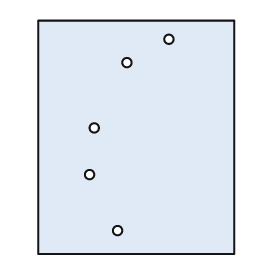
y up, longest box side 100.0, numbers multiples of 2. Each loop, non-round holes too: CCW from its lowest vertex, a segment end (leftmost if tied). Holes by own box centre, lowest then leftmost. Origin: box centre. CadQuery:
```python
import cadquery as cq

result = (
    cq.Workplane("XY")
    .moveTo(-42.0, -50.0)
    .lineTo(42.0, -50.0)
    .lineTo(42.0, 50.0)
    .lineTo(-42.0, 50.0)
    .close()
    .moveTo(-8.0, -40.0)
    .circle(2.0)
    .moveTo(-20.0, -16.0)
    .circle(2.0)
    .moveTo(-18.0, 4.0)
    .circle(2.0)
    .moveTo(-4.0, 32.0)
    .circle(2.0)
    .moveTo(14.0, 42.0)
    .circle(2.0)
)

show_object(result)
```